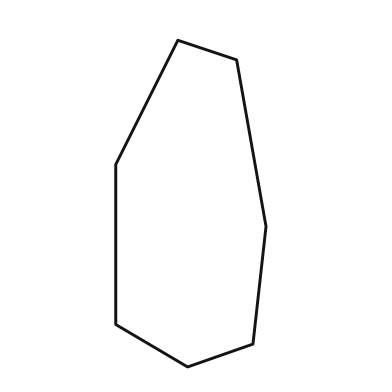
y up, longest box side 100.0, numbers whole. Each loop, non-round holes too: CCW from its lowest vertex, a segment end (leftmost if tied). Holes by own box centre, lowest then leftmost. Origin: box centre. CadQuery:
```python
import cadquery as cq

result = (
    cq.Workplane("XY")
    .moveTo(-1.0, -50.0)
    .lineTo(19.0, -43.0)
    .lineTo(23.0, -7.0)
    .lineTo(14.0, 44.0)
    .lineTo(-4.0, 50.0)
    .lineTo(-23.0, 12.0)
    .lineTo(-23.0, -37.0)
    .close()
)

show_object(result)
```